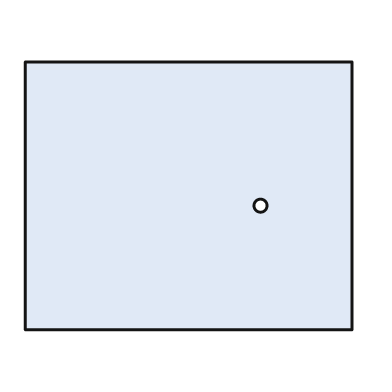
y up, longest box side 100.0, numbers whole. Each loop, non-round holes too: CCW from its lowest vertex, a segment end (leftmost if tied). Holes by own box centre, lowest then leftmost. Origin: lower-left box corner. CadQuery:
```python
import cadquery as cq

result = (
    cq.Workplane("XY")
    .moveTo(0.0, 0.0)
    .lineTo(100.0, 0.0)
    .lineTo(100.0, 82.0)
    .lineTo(0.0, 82.0)
    .close()
    .moveTo(72.0, 38.0)
    .circle(2.0)
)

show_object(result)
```